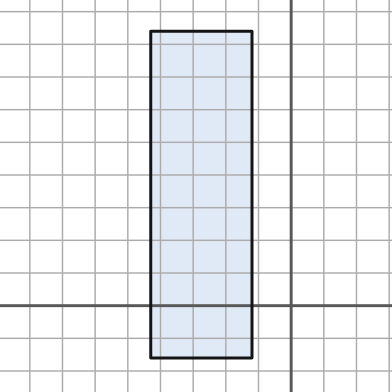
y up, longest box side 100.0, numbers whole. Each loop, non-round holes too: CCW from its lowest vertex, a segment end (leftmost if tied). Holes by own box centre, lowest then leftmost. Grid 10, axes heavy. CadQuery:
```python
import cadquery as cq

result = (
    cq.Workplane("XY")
    .moveTo(-43.0, -16.0)
    .lineTo(-12.0, -16.0)
    .lineTo(-12.0, 84.0)
    .lineTo(-43.0, 84.0)
    .close()
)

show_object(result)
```